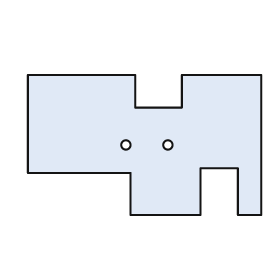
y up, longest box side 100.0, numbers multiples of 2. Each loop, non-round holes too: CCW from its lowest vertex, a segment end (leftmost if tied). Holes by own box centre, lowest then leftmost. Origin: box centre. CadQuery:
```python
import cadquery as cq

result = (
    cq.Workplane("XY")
    .moveTo(-6.0, -30.0)
    .lineTo(24.0, -30.0)
    .lineTo(24.0, -10.0)
    .lineTo(40.0, -10.0)
    .lineTo(40.0, -30.0)
    .lineTo(50.0, -30.0)
    .lineTo(50.0, 30.0)
    .lineTo(16.0, 30.0)
    .lineTo(16.0, 16.0)
    .lineTo(-4.0, 16.0)
    .lineTo(-4.0, 30.0)
    .lineTo(-50.0, 30.0)
    .lineTo(-50.0, -12.0)
    .lineTo(-6.0, -12.0)
    .close()
    .moveTo(-8.0, 0.0)
    .circle(2.0)
    .moveTo(10.0, 0.0)
    .circle(2.0)
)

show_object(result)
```